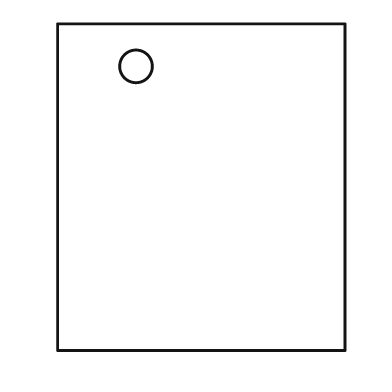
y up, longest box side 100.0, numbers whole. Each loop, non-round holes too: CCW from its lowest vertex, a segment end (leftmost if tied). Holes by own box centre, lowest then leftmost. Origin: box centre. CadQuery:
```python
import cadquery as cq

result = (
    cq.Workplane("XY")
    .moveTo(-44.0, -50.0)
    .lineTo(44.0, -50.0)
    .lineTo(44.0, 50.0)
    .lineTo(-44.0, 50.0)
    .close()
    .moveTo(-20.0, 37.0)
    .circle(5.0)
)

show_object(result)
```